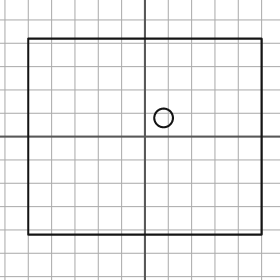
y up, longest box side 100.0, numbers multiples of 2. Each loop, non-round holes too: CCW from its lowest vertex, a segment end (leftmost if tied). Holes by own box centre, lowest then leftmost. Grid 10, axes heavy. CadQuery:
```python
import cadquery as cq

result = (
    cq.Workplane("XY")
    .moveTo(-50.0, -42.0)
    .lineTo(50.0, -42.0)
    .lineTo(50.0, 42.0)
    .lineTo(-50.0, 42.0)
    .close()
    .moveTo(8.0, 8.0)
    .circle(4.0)
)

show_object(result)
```